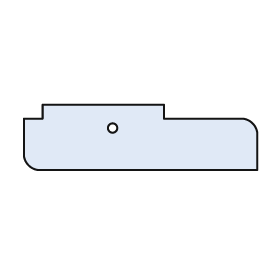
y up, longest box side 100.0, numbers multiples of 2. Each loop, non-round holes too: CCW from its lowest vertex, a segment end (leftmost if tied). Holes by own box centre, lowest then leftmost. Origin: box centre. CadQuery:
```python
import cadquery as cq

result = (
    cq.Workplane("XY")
    .moveTo(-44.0, -14.0)
    .lineTo(50.0, -14.0)
    .lineTo(50.0, 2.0)
    .threePointArc((48.0, 6.0), (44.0, 8.0))
    .lineTo(10.0, 8.0)
    .lineTo(10.0, 14.0)
    .lineTo(-42.0, 14.0)
    .lineTo(-42.0, 8.0)
    .lineTo(-50.0, 8.0)
    .lineTo(-50.0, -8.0)
    .threePointArc((-48.0, -12.0), (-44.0, -14.0))
    .close()
    .moveTo(-12.0, 4.0)
    .circle(2.0)
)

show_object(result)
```